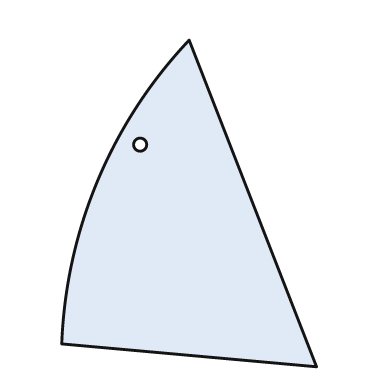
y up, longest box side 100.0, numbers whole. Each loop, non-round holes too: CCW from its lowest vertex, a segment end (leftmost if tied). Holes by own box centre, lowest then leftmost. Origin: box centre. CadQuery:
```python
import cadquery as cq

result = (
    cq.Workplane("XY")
    .moveTo(39.0, -50.0)
    .lineTo(0.0, 50.0)
    .threePointArc((-28.0, 7.0), (-39.0, -43.0))
    .close()
    .moveTo(-15.0, 18.0)
    .circle(2.0)
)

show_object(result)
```